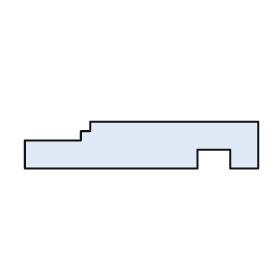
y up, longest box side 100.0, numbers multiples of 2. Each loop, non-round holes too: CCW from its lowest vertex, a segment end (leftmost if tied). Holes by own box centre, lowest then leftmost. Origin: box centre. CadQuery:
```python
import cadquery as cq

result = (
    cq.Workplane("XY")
    .moveTo(-50.0, -10.0)
    .lineTo(24.0, -10.0)
    .lineTo(24.0, -2.0)
    .lineTo(38.0, -2.0)
    .lineTo(38.0, -10.0)
    .lineTo(50.0, -10.0)
    .lineTo(50.0, 10.0)
    .lineTo(-22.0, 10.0)
    .lineTo(-22.0, 6.0)
    .lineTo(-26.0, 6.0)
    .lineTo(-26.0, 2.0)
    .lineTo(-50.0, 2.0)
    .close()
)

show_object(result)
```